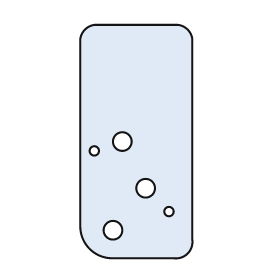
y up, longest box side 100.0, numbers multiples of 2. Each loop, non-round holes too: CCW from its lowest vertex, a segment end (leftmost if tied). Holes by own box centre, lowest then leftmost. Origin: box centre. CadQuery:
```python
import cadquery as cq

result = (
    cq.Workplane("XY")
    .moveTo(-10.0, -50.0)
    .lineTo(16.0, -50.0)
    .threePointArc((22.0, -48.0), (24.0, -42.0))
    .lineTo(24.0, 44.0)
    .threePointArc((22.0, 48.0), (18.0, 50.0))
    .lineTo(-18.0, 50.0)
    .threePointArc((-22.0, 48.0), (-24.0, 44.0))
    .lineTo(-24.0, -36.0)
    .threePointArc((-20.0, -46.0), (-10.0, -50.0))
    .close()
    .moveTo(-10.0, -38.0)
    .circle(4.0)
    .moveTo(14.0, -30.0)
    .circle(2.0)
    .moveTo(4.0, -20.0)
    .circle(4.0)
    .moveTo(-18.0, -4.0)
    .circle(2.0)
    .moveTo(-6.0, 0.0)
    .circle(4.0)
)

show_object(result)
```